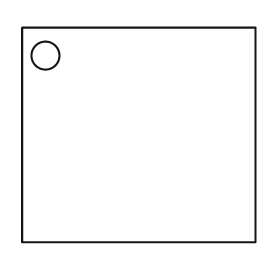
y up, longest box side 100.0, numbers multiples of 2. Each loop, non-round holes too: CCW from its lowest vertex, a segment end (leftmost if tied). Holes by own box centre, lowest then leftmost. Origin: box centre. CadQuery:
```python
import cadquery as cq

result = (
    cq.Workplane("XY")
    .moveTo(-50.0, -46.0)
    .lineTo(50.0, -46.0)
    .lineTo(50.0, 46.0)
    .lineTo(-50.0, 46.0)
    .close()
    .moveTo(-40.0, 34.0)
    .circle(6.0)
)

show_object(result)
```